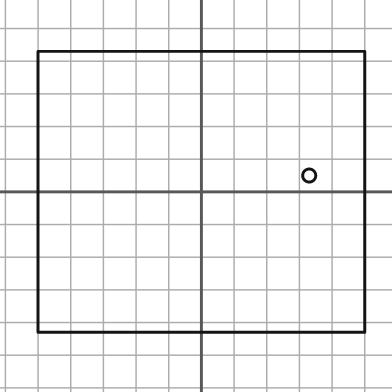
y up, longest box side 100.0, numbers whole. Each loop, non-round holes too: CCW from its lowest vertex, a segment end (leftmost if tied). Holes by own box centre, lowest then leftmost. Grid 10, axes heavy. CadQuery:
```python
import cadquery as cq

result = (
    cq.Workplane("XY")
    .moveTo(-50.0, -43.0)
    .lineTo(50.0, -43.0)
    .lineTo(50.0, 43.0)
    .lineTo(-50.0, 43.0)
    .close()
    .moveTo(33.0, 5.0)
    .circle(2.0)
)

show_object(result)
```